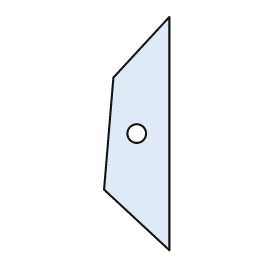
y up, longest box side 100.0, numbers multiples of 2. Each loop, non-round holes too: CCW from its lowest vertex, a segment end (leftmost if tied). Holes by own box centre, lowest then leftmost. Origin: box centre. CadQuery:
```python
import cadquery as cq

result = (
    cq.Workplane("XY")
    .moveTo(14.0, -50.0)
    .lineTo(14.0, 50.0)
    .lineTo(-10.0, 24.0)
    .lineTo(-14.0, -24.0)
    .close()
    .moveTo(0.0, 0.0)
    .circle(4.0)
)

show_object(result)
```